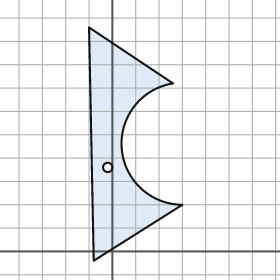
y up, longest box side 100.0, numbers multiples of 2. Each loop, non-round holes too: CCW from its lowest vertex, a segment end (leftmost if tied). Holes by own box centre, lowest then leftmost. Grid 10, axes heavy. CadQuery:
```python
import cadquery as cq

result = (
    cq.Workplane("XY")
    .moveTo(-8.0, -4.0)
    .lineTo(30.0, 20.0)
    .threePointArc((4.0, 44.0), (26.0, 72.0))
    .lineTo(-10.0, 96.0)
    .close()
    .moveTo(-2.0, 36.0)
    .circle(2.0)
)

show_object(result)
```